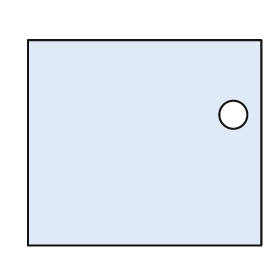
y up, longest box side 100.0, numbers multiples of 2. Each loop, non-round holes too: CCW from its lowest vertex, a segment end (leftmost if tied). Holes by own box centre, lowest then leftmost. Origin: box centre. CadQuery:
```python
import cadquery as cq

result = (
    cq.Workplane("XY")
    .moveTo(-50.0, -44.0)
    .lineTo(50.0, -44.0)
    .lineTo(50.0, 44.0)
    .lineTo(-50.0, 44.0)
    .close()
    .moveTo(38.0, 12.0)
    .circle(6.0)
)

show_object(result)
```